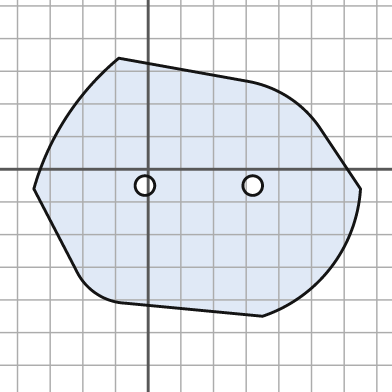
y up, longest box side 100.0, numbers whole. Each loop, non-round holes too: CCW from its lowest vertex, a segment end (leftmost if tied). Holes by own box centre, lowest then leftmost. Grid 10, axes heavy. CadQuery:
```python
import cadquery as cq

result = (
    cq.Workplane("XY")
    .moveTo(35.0, -45.0)
    .threePointArc((56.0, -30.0), (65.0, -6.0))
    .lineTo(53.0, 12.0)
    .threePointArc((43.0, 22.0), (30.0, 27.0))
    .lineTo(-9.0, 34.0)
    .threePointArc((-25.0, 16.0), (-35.0, -6.0))
    .lineTo(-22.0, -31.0)
    .threePointArc((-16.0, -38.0), (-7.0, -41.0))
    .close()
    .moveTo(-1.0, -5.0)
    .circle(3.0)
    .moveTo(32.0, -5.0)
    .circle(3.0)
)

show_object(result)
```